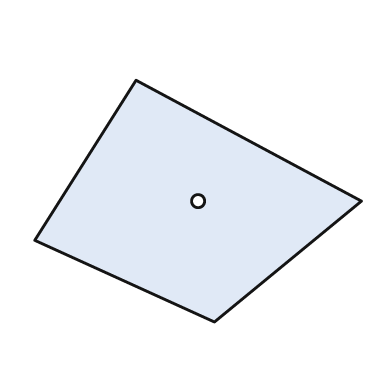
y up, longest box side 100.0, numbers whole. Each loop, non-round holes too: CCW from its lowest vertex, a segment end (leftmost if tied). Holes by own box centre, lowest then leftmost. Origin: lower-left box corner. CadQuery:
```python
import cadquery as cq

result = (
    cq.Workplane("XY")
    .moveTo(55.0, 0.0)
    .lineTo(100.0, 37.0)
    .lineTo(31.0, 74.0)
    .lineTo(0.0, 25.0)
    .close()
    .moveTo(50.0, 37.0)
    .circle(2.0)
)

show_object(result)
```